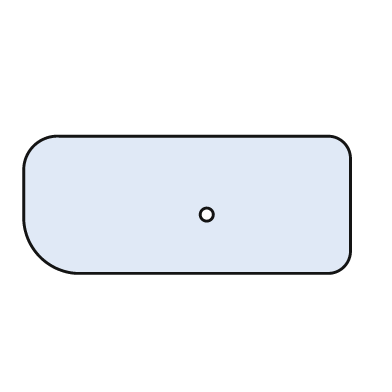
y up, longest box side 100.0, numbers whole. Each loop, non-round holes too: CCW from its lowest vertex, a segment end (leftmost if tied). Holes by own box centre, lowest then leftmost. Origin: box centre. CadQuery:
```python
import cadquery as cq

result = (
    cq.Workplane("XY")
    .moveTo(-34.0, -21.0)
    .lineTo(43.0, -21.0)
    .threePointArc((48.0, -19.0), (50.0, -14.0))
    .lineTo(50.0, 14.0)
    .threePointArc((48.0, 19.0), (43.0, 21.0))
    .lineTo(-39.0, 21.0)
    .threePointArc((-47.0, 18.0), (-50.0, 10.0))
    .lineTo(-50.0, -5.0)
    .threePointArc((-45.0, -16.0), (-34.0, -21.0))
    .close()
    .moveTo(6.0, -3.0)
    .circle(2.0)
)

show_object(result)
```